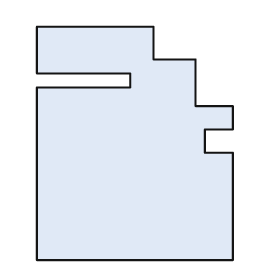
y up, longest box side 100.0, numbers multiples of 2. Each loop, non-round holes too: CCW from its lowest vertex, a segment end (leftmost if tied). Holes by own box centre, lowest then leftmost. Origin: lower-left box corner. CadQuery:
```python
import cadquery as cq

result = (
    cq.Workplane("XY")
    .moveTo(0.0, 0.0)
    .lineTo(84.0, 0.0)
    .lineTo(84.0, 46.0)
    .lineTo(72.0, 46.0)
    .lineTo(72.0, 56.0)
    .lineTo(84.0, 56.0)
    .lineTo(84.0, 66.0)
    .lineTo(68.0, 66.0)
    .lineTo(68.0, 86.0)
    .lineTo(50.0, 86.0)
    .lineTo(50.0, 100.0)
    .lineTo(0.0, 100.0)
    .lineTo(0.0, 80.0)
    .lineTo(40.0, 80.0)
    .lineTo(40.0, 74.0)
    .lineTo(0.0, 74.0)
    .close()
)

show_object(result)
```